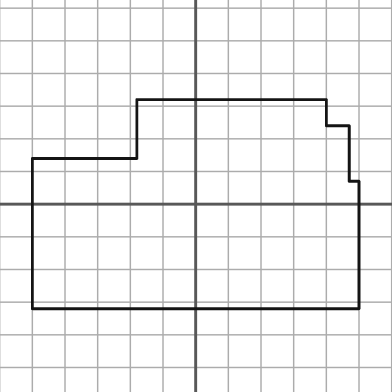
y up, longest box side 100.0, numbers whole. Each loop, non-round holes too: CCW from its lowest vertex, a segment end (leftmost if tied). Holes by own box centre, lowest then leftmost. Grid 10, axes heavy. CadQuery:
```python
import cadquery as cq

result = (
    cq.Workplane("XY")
    .moveTo(-50.0, -32.0)
    .lineTo(50.0, -32.0)
    .lineTo(50.0, 7.0)
    .lineTo(47.0, 7.0)
    .lineTo(47.0, 24.0)
    .lineTo(40.0, 24.0)
    .lineTo(40.0, 32.0)
    .lineTo(-18.0, 32.0)
    .lineTo(-18.0, 14.0)
    .lineTo(-50.0, 14.0)
    .close()
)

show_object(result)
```